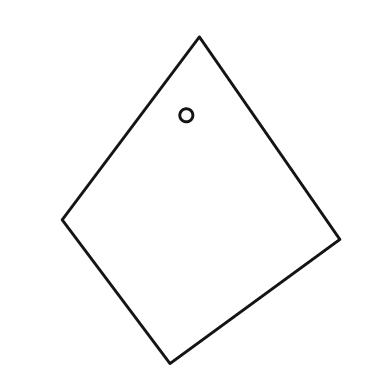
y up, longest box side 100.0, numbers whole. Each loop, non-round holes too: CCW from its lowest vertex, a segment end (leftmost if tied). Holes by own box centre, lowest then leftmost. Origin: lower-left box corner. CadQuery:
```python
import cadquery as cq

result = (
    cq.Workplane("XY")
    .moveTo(33.0, 0.0)
    .lineTo(85.0, 38.0)
    .lineTo(42.0, 100.0)
    .lineTo(0.0, 44.0)
    .close()
    .moveTo(38.0, 76.0)
    .circle(2.0)
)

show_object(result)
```